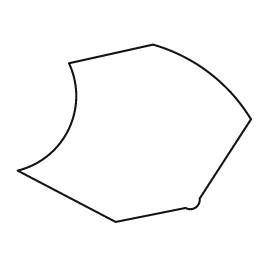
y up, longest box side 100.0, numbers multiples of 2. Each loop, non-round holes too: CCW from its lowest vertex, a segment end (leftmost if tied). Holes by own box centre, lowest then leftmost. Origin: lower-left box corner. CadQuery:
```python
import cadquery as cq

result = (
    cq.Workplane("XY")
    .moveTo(42.0, 0.0)
    .lineTo(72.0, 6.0)
    .threePointArc((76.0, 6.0), (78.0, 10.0))
    .lineTo(100.0, 44.0)
    .threePointArc((82.0, 64.0), (58.0, 76.0))
    .lineTo(22.0, 68.0)
    .threePointArc((22.0, 40.0), (0.0, 22.0))
    .close()
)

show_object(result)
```